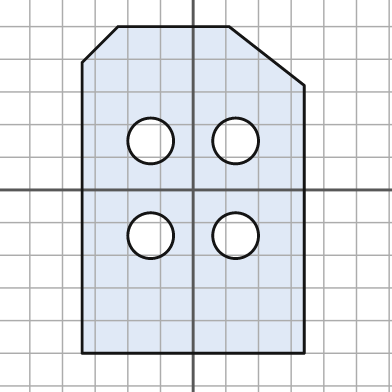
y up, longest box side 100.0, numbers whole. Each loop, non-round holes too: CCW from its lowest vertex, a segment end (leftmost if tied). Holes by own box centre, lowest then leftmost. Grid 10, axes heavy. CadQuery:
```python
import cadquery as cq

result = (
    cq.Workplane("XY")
    .moveTo(-34.0, -50.0)
    .lineTo(34.0, -50.0)
    .lineTo(34.0, 32.0)
    .lineTo(11.0, 50.0)
    .lineTo(-23.0, 50.0)
    .lineTo(-34.0, 39.0)
    .close()
    .moveTo(-13.0, -14.0)
    .circle(7.0)
    .moveTo(13.0, -14.0)
    .circle(7.0)
    .moveTo(-13.0, 15.0)
    .circle(7.0)
    .moveTo(13.0, 15.0)
    .circle(7.0)
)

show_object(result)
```